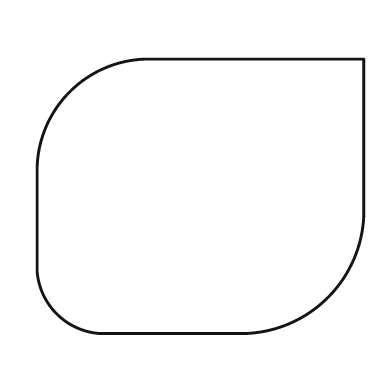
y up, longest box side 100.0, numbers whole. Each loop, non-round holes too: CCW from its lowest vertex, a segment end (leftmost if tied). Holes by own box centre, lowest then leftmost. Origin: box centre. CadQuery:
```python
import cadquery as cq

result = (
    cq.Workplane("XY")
    .moveTo(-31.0, -42.0)
    .lineTo(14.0, -42.0)
    .threePointArc((39.0, -31.0), (50.0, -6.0))
    .lineTo(50.0, 42.0)
    .lineTo(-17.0, 42.0)
    .threePointArc((-40.0, 32.0), (-50.0, 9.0))
    .lineTo(-50.0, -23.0)
    .threePointArc((-44.0, -36.0), (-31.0, -42.0))
    .close()
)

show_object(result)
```